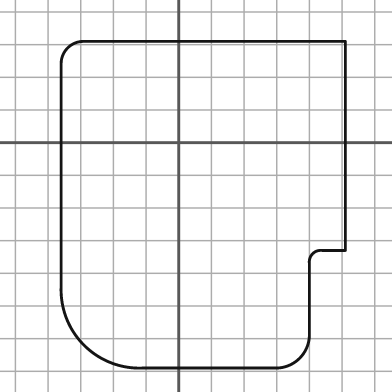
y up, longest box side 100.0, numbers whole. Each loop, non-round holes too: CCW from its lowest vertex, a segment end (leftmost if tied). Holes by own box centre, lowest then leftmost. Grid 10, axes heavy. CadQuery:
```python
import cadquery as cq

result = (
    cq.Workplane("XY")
    .moveTo(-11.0, -69.0)
    .lineTo(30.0, -69.0)
    .threePointArc((37.0, -66.0), (40.0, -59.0))
    .lineTo(40.0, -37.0)
    .threePointArc((41.0, -34.0), (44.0, -33.0))
    .lineTo(51.0, -33.0)
    .lineTo(51.0, 31.0)
    .lineTo(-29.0, 31.0)
    .threePointArc((-34.0, 29.0), (-36.0, 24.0))
    .lineTo(-36.0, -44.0)
    .threePointArc((-29.0, -62.0), (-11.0, -69.0))
    .close()
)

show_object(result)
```